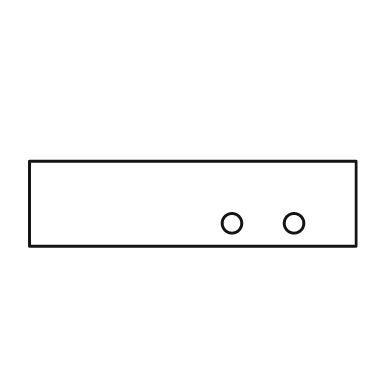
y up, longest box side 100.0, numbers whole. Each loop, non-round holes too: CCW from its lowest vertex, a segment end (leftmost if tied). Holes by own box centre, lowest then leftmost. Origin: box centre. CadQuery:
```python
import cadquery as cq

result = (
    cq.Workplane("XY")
    .moveTo(-50.0, -13.0)
    .lineTo(50.0, -13.0)
    .lineTo(50.0, 13.0)
    .lineTo(-50.0, 13.0)
    .close()
    .moveTo(12.0, -6.0)
    .circle(3.0)
    .moveTo(31.0, -6.0)
    .circle(3.0)
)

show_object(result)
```